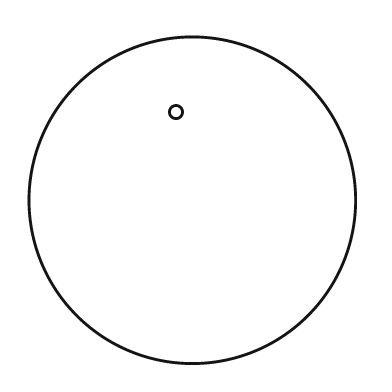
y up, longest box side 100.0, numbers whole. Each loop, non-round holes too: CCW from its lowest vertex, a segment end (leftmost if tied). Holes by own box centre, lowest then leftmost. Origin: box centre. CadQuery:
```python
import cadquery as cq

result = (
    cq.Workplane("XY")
    .moveTo(0.0, 0.0)
    .circle(50.0)
    .moveTo(-5.0, 27.0)
    .circle(2.0)
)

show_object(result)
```